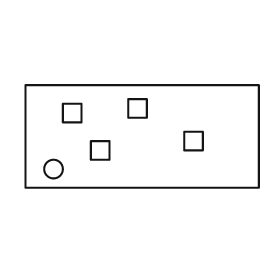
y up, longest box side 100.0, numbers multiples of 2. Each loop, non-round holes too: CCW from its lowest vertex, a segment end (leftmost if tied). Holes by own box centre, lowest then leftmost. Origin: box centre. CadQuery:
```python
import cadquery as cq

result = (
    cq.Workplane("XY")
    .moveTo(-50.0, -22.0)
    .lineTo(50.0, -22.0)
    .lineTo(50.0, 22.0)
    .lineTo(-50.0, 22.0)
    .close()
    .moveTo(-38.0, -14.0)
    .circle(4.0)
    .moveTo(-22.0, -10.0)
    .lineTo(-14.0, -10.0)
    .lineTo(-14.0, -2.0)
    .lineTo(-22.0, -2.0)
    .close()
    .moveTo(18.0, -6.0)
    .lineTo(26.0, -6.0)
    .lineTo(26.0, 2.0)
    .lineTo(18.0, 2.0)
    .close()
    .moveTo(-34.0, 6.0)
    .lineTo(-26.0, 6.0)
    .lineTo(-26.0, 14.0)
    .lineTo(-34.0, 14.0)
    .close()
    .moveTo(-6.0, 8.0)
    .lineTo(2.0, 8.0)
    .lineTo(2.0, 16.0)
    .lineTo(-6.0, 16.0)
    .close()
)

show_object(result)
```